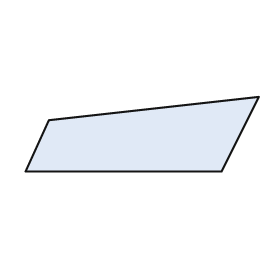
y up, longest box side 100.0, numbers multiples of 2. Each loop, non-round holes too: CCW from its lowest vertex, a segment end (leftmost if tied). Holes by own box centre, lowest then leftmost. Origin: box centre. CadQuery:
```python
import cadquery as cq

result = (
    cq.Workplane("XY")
    .moveTo(-50.0, -16.0)
    .lineTo(34.0, -16.0)
    .lineTo(50.0, 16.0)
    .lineTo(-40.0, 6.0)
    .close()
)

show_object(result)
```